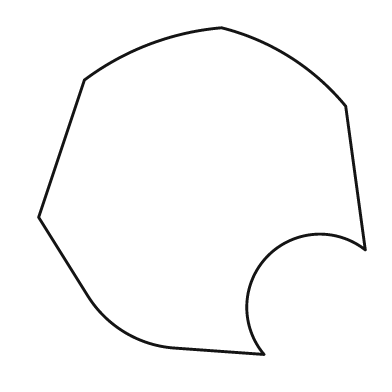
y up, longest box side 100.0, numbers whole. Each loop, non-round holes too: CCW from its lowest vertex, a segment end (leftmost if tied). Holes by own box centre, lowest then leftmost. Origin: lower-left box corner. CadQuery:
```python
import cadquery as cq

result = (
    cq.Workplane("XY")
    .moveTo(69.0, 0.0)
    .threePointArc((70.0, 30.0), (100.0, 32.0))
    .lineTo(94.0, 76.0)
    .threePointArc((77.0, 91.0), (56.0, 100.0))
    .threePointArc((34.0, 95.0), (14.0, 84.0))
    .lineTo(0.0, 42.0)
    .lineTo(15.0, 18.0)
    .threePointArc((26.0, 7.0), (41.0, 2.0))
    .close()
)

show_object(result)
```